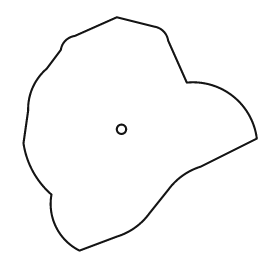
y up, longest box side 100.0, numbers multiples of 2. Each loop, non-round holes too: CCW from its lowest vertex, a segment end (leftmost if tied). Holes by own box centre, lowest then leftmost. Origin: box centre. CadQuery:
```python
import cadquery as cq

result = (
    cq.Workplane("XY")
    .moveTo(-26.0, -50.0)
    .lineTo(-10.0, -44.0)
    .threePointArc((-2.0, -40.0), (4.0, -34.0))
    .lineTo(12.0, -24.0)
    .threePointArc((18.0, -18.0), (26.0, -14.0))
    .lineTo(50.0, -2.0)
    .threePointArc((40.0, 16.0), (20.0, 22.0))
    .lineTo(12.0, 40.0)
    .threePointArc((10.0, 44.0), (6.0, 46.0))
    .lineTo(-10.0, 50.0)
    .lineTo(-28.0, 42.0)
    .threePointArc((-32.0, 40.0), (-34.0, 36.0))
    .lineTo(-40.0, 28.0)
    .threePointArc((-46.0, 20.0), (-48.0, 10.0))
    .lineTo(-50.0, -4.0)
    .threePointArc((-46.0, -16.0), (-38.0, -26.0))
    .threePointArc((-36.0, -40.0), (-26.0, -50.0))
    .close()
    .moveTo(-8.0, 2.0)
    .circle(2.0)
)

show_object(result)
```